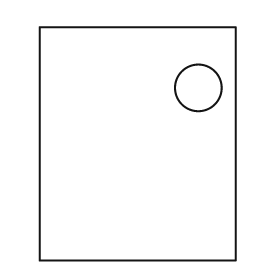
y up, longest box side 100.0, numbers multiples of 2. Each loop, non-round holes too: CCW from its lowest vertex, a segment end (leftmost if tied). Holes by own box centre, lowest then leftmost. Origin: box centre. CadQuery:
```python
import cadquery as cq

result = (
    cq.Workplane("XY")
    .moveTo(-42.0, -50.0)
    .lineTo(42.0, -50.0)
    .lineTo(42.0, 50.0)
    .lineTo(-42.0, 50.0)
    .close()
    .moveTo(26.0, 24.0)
    .circle(10.0)
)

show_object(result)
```